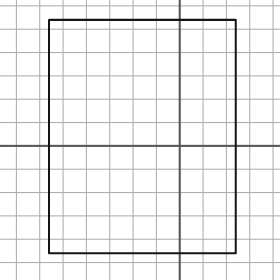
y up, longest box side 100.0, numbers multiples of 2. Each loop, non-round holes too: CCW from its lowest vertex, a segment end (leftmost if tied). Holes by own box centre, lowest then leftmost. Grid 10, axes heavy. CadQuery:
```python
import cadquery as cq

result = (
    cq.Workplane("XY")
    .moveTo(-56.0, -46.0)
    .lineTo(24.0, -46.0)
    .lineTo(24.0, 54.0)
    .lineTo(-56.0, 54.0)
    .close()
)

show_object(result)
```